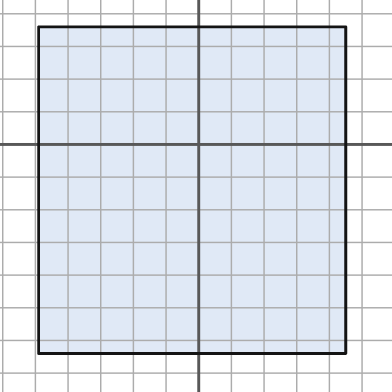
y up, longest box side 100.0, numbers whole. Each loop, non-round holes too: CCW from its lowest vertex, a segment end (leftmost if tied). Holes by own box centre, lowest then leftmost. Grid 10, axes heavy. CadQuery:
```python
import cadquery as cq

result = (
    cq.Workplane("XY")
    .moveTo(-49.0, -64.0)
    .lineTo(45.0, -64.0)
    .lineTo(45.0, 36.0)
    .lineTo(-49.0, 36.0)
    .close()
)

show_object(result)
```